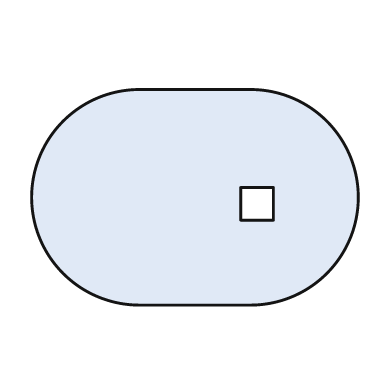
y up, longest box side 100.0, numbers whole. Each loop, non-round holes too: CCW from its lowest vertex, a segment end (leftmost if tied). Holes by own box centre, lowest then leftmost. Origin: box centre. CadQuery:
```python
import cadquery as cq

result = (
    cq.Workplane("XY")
    .moveTo(-17.0, -33.0)
    .lineTo(17.0, -33.0)
    .threePointArc((50.0, 0.0), (17.0, 33.0))
    .lineTo(-17.0, 33.0)
    .threePointArc((-50.0, 0.0), (-17.0, -33.0))
    .close()
    .moveTo(14.0, -7.0)
    .lineTo(24.0, -7.0)
    .lineTo(24.0, 3.0)
    .lineTo(14.0, 3.0)
    .close()
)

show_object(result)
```